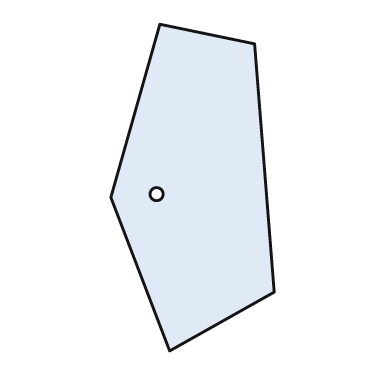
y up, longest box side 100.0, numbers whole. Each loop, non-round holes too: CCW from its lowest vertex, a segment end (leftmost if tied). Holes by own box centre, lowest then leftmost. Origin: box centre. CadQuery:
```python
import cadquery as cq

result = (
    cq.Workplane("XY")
    .moveTo(-7.0, -50.0)
    .lineTo(25.0, -32.0)
    .lineTo(19.0, 44.0)
    .lineTo(-10.0, 50.0)
    .lineTo(-25.0, -3.0)
    .close()
    .moveTo(-11.0, -2.0)
    .circle(2.0)
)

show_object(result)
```